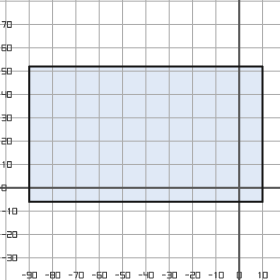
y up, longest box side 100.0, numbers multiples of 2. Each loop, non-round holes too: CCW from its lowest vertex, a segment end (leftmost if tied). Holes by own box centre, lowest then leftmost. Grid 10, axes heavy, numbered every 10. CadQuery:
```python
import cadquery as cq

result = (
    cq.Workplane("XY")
    .moveTo(-90.0, -6.0)
    .lineTo(10.0, -6.0)
    .lineTo(10.0, 52.0)
    .lineTo(-90.0, 52.0)
    .close()
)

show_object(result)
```